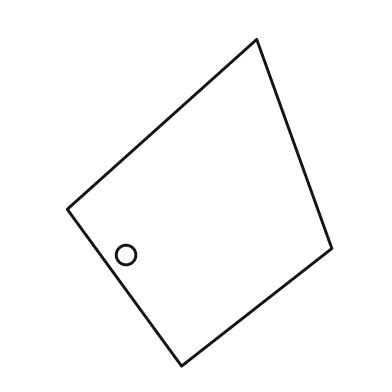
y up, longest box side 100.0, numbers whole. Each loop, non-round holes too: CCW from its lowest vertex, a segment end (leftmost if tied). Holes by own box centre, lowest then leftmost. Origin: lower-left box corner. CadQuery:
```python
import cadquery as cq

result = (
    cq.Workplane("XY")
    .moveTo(35.0, 0.0)
    .lineTo(81.0, 36.0)
    .lineTo(58.0, 100.0)
    .lineTo(0.0, 48.0)
    .close()
    .moveTo(18.0, 34.0)
    .circle(3.0)
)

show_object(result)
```